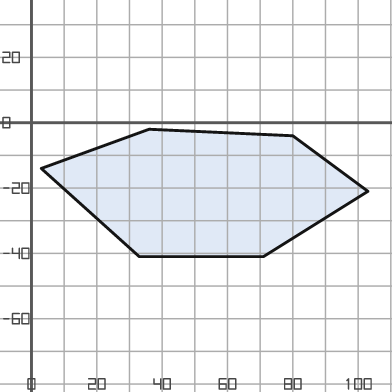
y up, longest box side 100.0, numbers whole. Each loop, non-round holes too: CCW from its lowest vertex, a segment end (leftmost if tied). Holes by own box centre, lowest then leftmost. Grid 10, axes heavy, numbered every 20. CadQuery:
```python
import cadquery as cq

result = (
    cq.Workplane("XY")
    .moveTo(33.0, -41.0)
    .lineTo(71.0, -41.0)
    .lineTo(103.0, -21.0)
    .lineTo(80.0, -4.0)
    .lineTo(36.0, -2.0)
    .lineTo(3.0, -14.0)
    .close()
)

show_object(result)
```